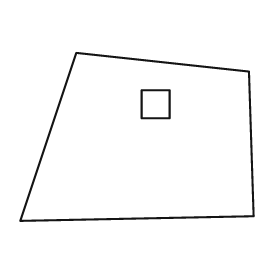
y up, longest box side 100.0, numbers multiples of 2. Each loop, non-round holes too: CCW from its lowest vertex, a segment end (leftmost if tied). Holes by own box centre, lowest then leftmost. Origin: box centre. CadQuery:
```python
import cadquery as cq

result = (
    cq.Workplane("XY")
    .moveTo(-50.0, -36.0)
    .lineTo(50.0, -34.0)
    .lineTo(48.0, 28.0)
    .lineTo(-26.0, 36.0)
    .close()
    .moveTo(2.0, 8.0)
    .lineTo(14.0, 8.0)
    .lineTo(14.0, 20.0)
    .lineTo(2.0, 20.0)
    .close()
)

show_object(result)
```